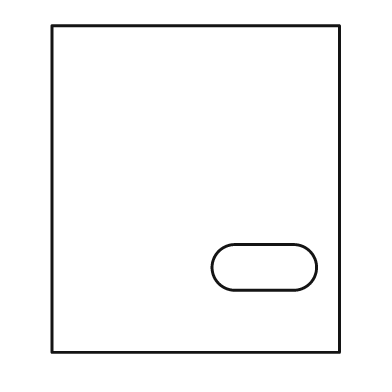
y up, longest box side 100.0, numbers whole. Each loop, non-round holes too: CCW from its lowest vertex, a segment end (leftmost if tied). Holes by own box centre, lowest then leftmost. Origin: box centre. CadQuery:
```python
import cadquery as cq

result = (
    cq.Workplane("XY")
    .moveTo(-44.0, -50.0)
    .lineTo(44.0, -50.0)
    .lineTo(44.0, 50.0)
    .lineTo(-44.0, 50.0)
    .close()
    .moveTo(12.0, -31.0)
    .lineTo(30.0, -31.0)
    .threePointArc((37.0, -24.0), (30.0, -17.0))
    .lineTo(12.0, -17.0)
    .threePointArc((5.0, -24.0), (12.0, -31.0))
    .close()
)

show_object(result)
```